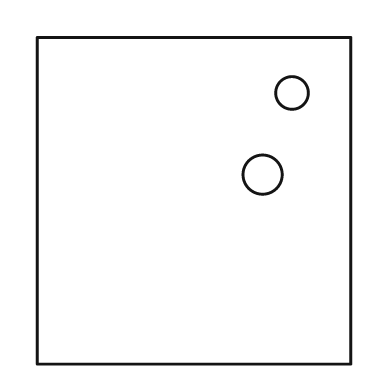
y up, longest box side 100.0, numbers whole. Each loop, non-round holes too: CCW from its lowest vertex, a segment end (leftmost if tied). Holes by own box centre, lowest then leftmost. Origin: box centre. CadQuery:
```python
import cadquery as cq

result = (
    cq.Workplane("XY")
    .moveTo(-48.0, -50.0)
    .lineTo(48.0, -50.0)
    .lineTo(48.0, 50.0)
    .lineTo(-48.0, 50.0)
    .close()
    .moveTo(21.0, 8.0)
    .circle(6.0)
    .moveTo(30.0, 33.0)
    .circle(5.0)
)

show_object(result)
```